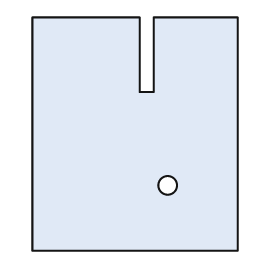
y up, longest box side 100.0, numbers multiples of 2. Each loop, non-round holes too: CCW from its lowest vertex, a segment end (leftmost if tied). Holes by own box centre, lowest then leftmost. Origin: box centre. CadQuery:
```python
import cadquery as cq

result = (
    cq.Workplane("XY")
    .moveTo(-44.0, -50.0)
    .lineTo(44.0, -50.0)
    .lineTo(44.0, 50.0)
    .lineTo(8.0, 50.0)
    .lineTo(8.0, 18.0)
    .lineTo(2.0, 18.0)
    .lineTo(2.0, 50.0)
    .lineTo(-44.0, 50.0)
    .close()
    .moveTo(14.0, -22.0)
    .circle(4.0)
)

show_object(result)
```